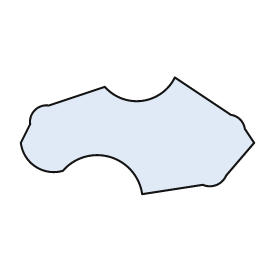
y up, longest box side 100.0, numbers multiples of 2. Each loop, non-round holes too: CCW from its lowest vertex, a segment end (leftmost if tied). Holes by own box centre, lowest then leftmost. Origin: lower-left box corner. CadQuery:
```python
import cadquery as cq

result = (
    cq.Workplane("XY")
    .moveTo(52.0, 0.0)
    .lineTo(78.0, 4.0)
    .threePointArc((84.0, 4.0), (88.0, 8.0))
    .lineTo(100.0, 22.0)
    .lineTo(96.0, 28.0)
    .threePointArc((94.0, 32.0), (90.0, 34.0))
    .lineTo(66.0, 50.0)
    .threePointArc((52.0, 40.0), (36.0, 46.0))
    .lineTo(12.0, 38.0)
    .threePointArc((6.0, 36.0), (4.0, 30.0))
    .lineTo(0.0, 22.0)
    .threePointArc((6.0, 12.0), (18.0, 10.0))
    .threePointArc((38.0, 16.0), (52.0, 0.0))
    .close()
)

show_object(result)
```